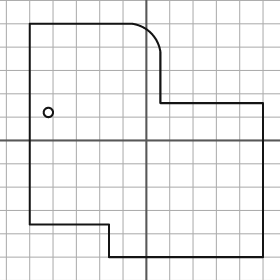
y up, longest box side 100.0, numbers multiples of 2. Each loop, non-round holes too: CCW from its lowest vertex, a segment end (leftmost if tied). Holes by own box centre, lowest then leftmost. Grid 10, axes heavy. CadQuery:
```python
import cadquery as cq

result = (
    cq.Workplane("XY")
    .moveTo(-16.0, -50.0)
    .lineTo(50.0, -50.0)
    .lineTo(50.0, 16.0)
    .lineTo(6.0, 16.0)
    .lineTo(6.0, 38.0)
    .threePointArc((2.0, 46.0), (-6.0, 50.0))
    .lineTo(-50.0, 50.0)
    .lineTo(-50.0, -36.0)
    .lineTo(-16.0, -36.0)
    .close()
    .moveTo(-42.0, 12.0)
    .circle(2.0)
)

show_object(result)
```